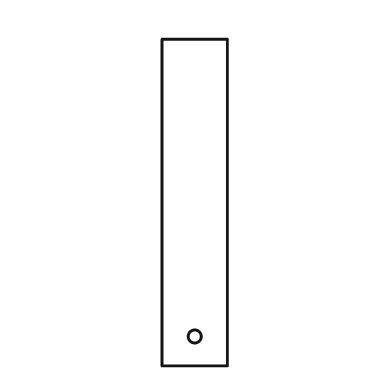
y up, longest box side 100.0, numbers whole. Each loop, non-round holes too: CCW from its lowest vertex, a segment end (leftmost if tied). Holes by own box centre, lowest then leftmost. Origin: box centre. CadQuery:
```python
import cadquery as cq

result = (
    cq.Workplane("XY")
    .moveTo(-10.0, -50.0)
    .lineTo(10.0, -50.0)
    .lineTo(10.0, 50.0)
    .lineTo(-10.0, 50.0)
    .close()
    .moveTo(0.0, -41.0)
    .circle(2.0)
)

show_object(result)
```